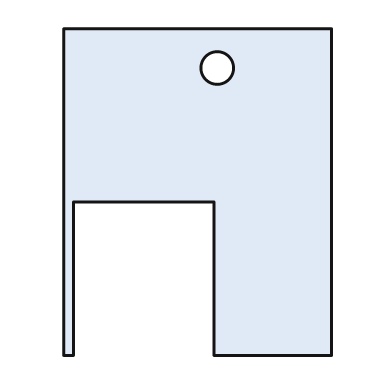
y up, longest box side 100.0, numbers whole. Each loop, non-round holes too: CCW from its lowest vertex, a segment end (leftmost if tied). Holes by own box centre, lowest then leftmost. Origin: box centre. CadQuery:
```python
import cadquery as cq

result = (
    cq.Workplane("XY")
    .moveTo(-41.0, -50.0)
    .lineTo(-38.0, -50.0)
    .lineTo(-38.0, -3.0)
    .lineTo(5.0, -3.0)
    .lineTo(5.0, -50.0)
    .lineTo(41.0, -50.0)
    .lineTo(41.0, 50.0)
    .lineTo(-41.0, 50.0)
    .close()
    .moveTo(6.0, 38.0)
    .circle(5.0)
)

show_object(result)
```